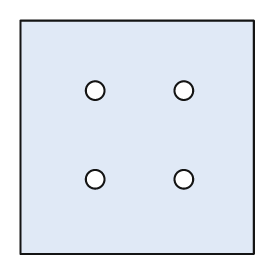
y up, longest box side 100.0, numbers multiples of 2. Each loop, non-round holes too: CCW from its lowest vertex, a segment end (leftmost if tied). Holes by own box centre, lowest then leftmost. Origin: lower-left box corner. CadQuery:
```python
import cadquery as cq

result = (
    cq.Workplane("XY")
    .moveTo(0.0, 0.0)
    .lineTo(100.0, 0.0)
    .lineTo(100.0, 100.0)
    .lineTo(0.0, 100.0)
    .close()
    .moveTo(32.0, 32.0)
    .circle(4.0)
    .moveTo(70.0, 32.0)
    .circle(4.0)
    .moveTo(32.0, 70.0)
    .circle(4.0)
    .moveTo(70.0, 70.0)
    .circle(4.0)
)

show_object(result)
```